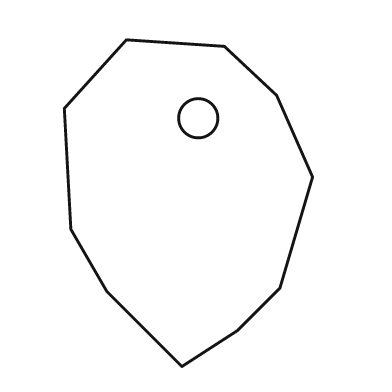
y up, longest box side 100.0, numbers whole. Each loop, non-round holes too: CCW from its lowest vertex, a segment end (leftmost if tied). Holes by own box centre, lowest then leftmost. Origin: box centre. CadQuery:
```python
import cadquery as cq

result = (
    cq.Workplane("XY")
    .moveTo(-2.0, -50.0)
    .lineTo(15.0, -39.0)
    .lineTo(28.0, -26.0)
    .lineTo(38.0, 8.0)
    .lineTo(27.0, 33.0)
    .lineTo(11.0, 48.0)
    .lineTo(-19.0, 50.0)
    .lineTo(-38.0, 29.0)
    .lineTo(-36.0, -8.0)
    .lineTo(-25.0, -27.0)
    .close()
    .moveTo(3.0, 26.0)
    .circle(6.0)
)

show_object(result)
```